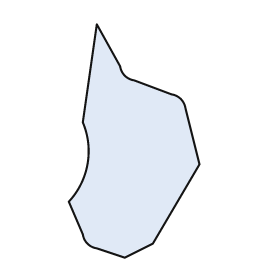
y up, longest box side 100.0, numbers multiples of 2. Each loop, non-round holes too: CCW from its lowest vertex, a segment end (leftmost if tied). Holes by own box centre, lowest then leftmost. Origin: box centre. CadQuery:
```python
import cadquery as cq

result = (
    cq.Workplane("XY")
    .moveTo(-4.0, -50.0)
    .lineTo(8.0, -44.0)
    .lineTo(28.0, -10.0)
    .lineTo(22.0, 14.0)
    .threePointArc((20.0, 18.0), (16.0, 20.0))
    .lineTo(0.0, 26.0)
    .threePointArc((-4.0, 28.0), (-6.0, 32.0))
    .lineTo(-16.0, 50.0)
    .lineTo(-22.0, 8.0)
    .threePointArc((-20.0, -10.0), (-28.0, -26.0))
    .lineTo(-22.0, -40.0)
    .threePointArc((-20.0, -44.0), (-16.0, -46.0))
    .close()
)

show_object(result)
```